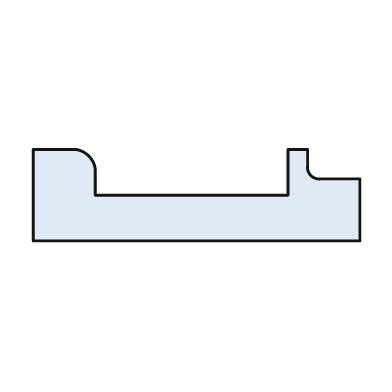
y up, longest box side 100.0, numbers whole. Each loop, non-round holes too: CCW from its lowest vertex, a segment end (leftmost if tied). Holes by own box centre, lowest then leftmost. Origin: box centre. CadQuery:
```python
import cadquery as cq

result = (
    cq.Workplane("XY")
    .moveTo(-50.0, -14.0)
    .lineTo(50.0, -14.0)
    .lineTo(50.0, 5.0)
    .lineTo(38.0, 5.0)
    .threePointArc((35.0, 6.0), (34.0, 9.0))
    .lineTo(34.0, 14.0)
    .lineTo(28.0, 14.0)
    .lineTo(28.0, 0.0)
    .lineTo(-31.0, 0.0)
    .lineTo(-31.0, 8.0)
    .threePointArc((-33.0, 12.0), (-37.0, 14.0))
    .lineTo(-50.0, 14.0)
    .close()
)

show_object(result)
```